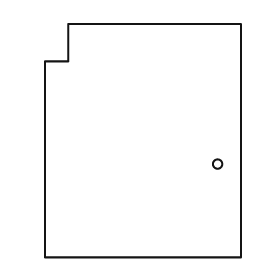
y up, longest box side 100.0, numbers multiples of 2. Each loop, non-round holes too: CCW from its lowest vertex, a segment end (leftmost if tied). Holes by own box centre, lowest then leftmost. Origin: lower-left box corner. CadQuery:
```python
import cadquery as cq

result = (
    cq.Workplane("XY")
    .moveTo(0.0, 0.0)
    .lineTo(84.0, 0.0)
    .lineTo(84.0, 100.0)
    .lineTo(10.0, 100.0)
    .lineTo(10.0, 84.0)
    .lineTo(0.0, 84.0)
    .close()
    .moveTo(74.0, 40.0)
    .circle(2.0)
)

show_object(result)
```